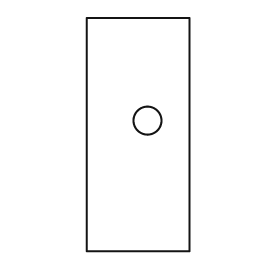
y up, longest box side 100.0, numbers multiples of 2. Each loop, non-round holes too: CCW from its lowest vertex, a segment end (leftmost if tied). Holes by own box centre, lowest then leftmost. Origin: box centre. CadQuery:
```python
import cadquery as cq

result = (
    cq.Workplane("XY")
    .moveTo(-22.0, -50.0)
    .lineTo(22.0, -50.0)
    .lineTo(22.0, 50.0)
    .lineTo(-22.0, 50.0)
    .close()
    .moveTo(4.0, 6.0)
    .circle(6.0)
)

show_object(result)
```